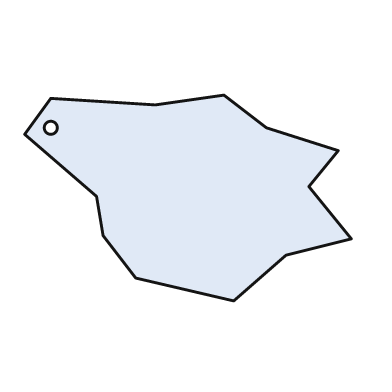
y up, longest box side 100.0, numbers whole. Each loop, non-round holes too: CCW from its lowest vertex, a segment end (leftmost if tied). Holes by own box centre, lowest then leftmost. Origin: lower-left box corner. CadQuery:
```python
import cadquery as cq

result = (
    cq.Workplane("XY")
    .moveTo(64.0, 0.0)
    .lineTo(80.0, 14.0)
    .lineTo(100.0, 19.0)
    .lineTo(87.0, 35.0)
    .lineTo(96.0, 46.0)
    .lineTo(74.0, 53.0)
    .lineTo(61.0, 63.0)
    .lineTo(40.0, 60.0)
    .lineTo(8.0, 62.0)
    .lineTo(0.0, 51.0)
    .lineTo(22.0, 32.0)
    .lineTo(24.0, 20.0)
    .lineTo(34.0, 7.0)
    .close()
    .moveTo(8.0, 53.0)
    .circle(2.0)
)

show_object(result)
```